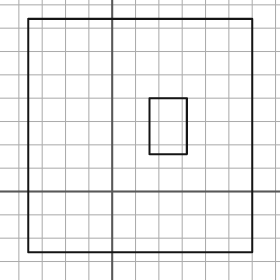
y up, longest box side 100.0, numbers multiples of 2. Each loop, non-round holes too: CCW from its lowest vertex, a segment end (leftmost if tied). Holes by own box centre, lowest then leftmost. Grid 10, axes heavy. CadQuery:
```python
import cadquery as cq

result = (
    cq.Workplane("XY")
    .moveTo(-36.0, -26.0)
    .lineTo(60.0, -26.0)
    .lineTo(60.0, 74.0)
    .lineTo(-36.0, 74.0)
    .close()
    .moveTo(16.0, 16.0)
    .lineTo(32.0, 16.0)
    .lineTo(32.0, 40.0)
    .lineTo(16.0, 40.0)
    .close()
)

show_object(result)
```